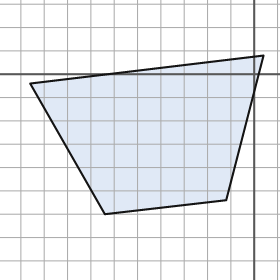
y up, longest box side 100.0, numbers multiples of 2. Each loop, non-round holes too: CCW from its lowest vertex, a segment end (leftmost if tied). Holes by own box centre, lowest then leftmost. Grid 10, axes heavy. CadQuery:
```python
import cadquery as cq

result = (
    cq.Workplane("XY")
    .moveTo(-64.0, -60.0)
    .lineTo(-12.0, -54.0)
    .lineTo(4.0, 8.0)
    .lineTo(-96.0, -4.0)
    .close()
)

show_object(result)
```